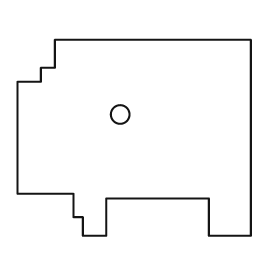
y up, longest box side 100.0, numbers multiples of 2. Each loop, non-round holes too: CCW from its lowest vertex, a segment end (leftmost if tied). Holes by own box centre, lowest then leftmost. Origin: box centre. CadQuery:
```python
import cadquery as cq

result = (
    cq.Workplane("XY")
    .moveTo(-22.0, -42.0)
    .lineTo(-12.0, -42.0)
    .lineTo(-12.0, -26.0)
    .lineTo(32.0, -26.0)
    .lineTo(32.0, -42.0)
    .lineTo(50.0, -42.0)
    .lineTo(50.0, 42.0)
    .lineTo(-34.0, 42.0)
    .lineTo(-34.0, 30.0)
    .lineTo(-40.0, 30.0)
    .lineTo(-40.0, 24.0)
    .lineTo(-50.0, 24.0)
    .lineTo(-50.0, -24.0)
    .lineTo(-26.0, -24.0)
    .lineTo(-26.0, -34.0)
    .lineTo(-22.0, -34.0)
    .close()
    .moveTo(-6.0, 10.0)
    .circle(4.0)
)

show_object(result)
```